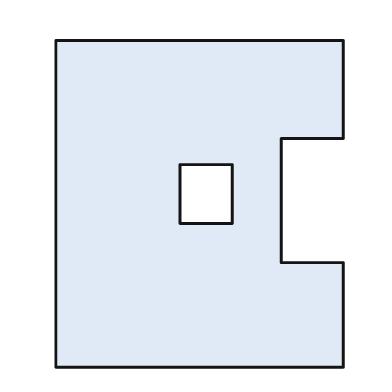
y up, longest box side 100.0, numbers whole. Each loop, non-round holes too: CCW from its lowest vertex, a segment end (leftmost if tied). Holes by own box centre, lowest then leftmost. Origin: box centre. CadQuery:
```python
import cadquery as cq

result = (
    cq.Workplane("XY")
    .moveTo(-44.0, -50.0)
    .lineTo(44.0, -50.0)
    .lineTo(44.0, -18.0)
    .lineTo(25.0, -18.0)
    .lineTo(25.0, 20.0)
    .lineTo(44.0, 20.0)
    .lineTo(44.0, 50.0)
    .lineTo(-44.0, 50.0)
    .close()
    .moveTo(-6.0, -6.0)
    .lineTo(10.0, -6.0)
    .lineTo(10.0, 12.0)
    .lineTo(-6.0, 12.0)
    .close()
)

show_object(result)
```